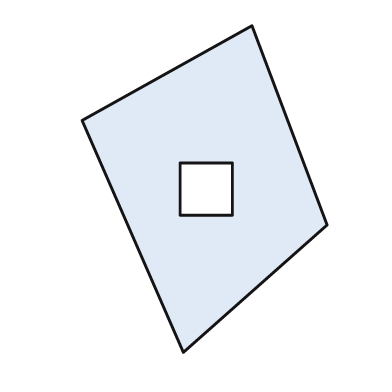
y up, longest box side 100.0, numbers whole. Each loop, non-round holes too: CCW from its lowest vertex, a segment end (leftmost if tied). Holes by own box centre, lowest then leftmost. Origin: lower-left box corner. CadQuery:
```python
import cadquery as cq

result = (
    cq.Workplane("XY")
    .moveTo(31.0, 0.0)
    .lineTo(75.0, 39.0)
    .lineTo(52.0, 100.0)
    .lineTo(0.0, 71.0)
    .close()
    .moveTo(30.0, 42.0)
    .lineTo(46.0, 42.0)
    .lineTo(46.0, 58.0)
    .lineTo(30.0, 58.0)
    .close()
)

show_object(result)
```